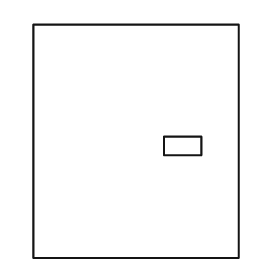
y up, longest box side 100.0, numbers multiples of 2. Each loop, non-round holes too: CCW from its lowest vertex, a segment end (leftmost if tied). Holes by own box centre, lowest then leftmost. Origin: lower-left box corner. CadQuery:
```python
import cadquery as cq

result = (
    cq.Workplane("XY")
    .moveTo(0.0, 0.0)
    .lineTo(88.0, 0.0)
    .lineTo(88.0, 100.0)
    .lineTo(0.0, 100.0)
    .close()
    .moveTo(56.0, 44.0)
    .lineTo(72.0, 44.0)
    .lineTo(72.0, 52.0)
    .lineTo(56.0, 52.0)
    .close()
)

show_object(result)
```